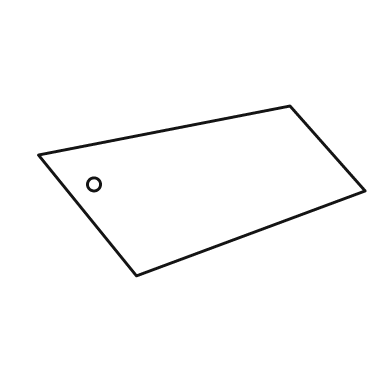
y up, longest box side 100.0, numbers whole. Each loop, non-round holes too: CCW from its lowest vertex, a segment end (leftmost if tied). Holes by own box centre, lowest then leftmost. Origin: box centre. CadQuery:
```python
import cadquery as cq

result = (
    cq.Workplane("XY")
    .moveTo(-20.0, -26.0)
    .lineTo(50.0, 0.0)
    .lineTo(27.0, 26.0)
    .lineTo(-50.0, 11.0)
    .close()
    .moveTo(-33.0, 2.0)
    .circle(2.0)
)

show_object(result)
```